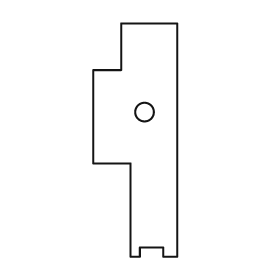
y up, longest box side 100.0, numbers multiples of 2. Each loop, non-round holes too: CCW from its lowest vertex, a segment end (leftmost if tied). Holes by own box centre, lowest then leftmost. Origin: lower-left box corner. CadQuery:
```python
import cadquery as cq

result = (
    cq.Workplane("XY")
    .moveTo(16.0, 0.0)
    .lineTo(20.0, 0.0)
    .lineTo(20.0, 4.0)
    .lineTo(30.0, 4.0)
    .lineTo(30.0, 0.0)
    .lineTo(36.0, 0.0)
    .lineTo(36.0, 100.0)
    .lineTo(12.0, 100.0)
    .lineTo(12.0, 80.0)
    .lineTo(0.0, 80.0)
    .lineTo(0.0, 40.0)
    .lineTo(16.0, 40.0)
    .close()
    .moveTo(22.0, 62.0)
    .circle(4.0)
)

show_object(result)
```